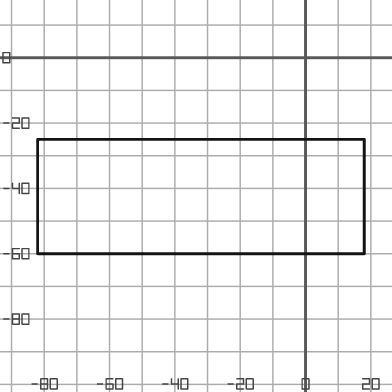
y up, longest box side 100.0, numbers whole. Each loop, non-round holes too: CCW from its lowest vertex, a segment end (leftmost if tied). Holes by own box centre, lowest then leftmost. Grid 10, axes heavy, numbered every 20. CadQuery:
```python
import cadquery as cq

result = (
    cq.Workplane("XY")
    .moveTo(-82.0, -60.0)
    .lineTo(18.0, -60.0)
    .lineTo(18.0, -25.0)
    .lineTo(-82.0, -25.0)
    .close()
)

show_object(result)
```